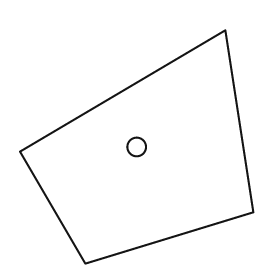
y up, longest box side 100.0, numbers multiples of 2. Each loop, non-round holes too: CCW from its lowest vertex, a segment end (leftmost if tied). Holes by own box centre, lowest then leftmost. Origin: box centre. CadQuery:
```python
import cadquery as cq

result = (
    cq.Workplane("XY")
    .moveTo(-22.0, -50.0)
    .lineTo(50.0, -28.0)
    .lineTo(38.0, 50.0)
    .lineTo(-50.0, -2.0)
    .close()
    .moveTo(0.0, 0.0)
    .circle(4.0)
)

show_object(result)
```